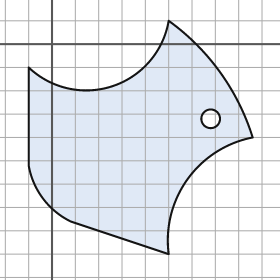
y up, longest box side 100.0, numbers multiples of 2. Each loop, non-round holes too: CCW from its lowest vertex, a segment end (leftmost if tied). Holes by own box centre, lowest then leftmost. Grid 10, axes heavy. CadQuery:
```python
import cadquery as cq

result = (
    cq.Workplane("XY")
    .moveTo(50.0, -90.0)
    .threePointArc((58.0, -58.0), (86.0, -40.0))
    .threePointArc((72.0, -12.0), (50.0, 10.0))
    .threePointArc((26.0, -18.0), (-10.0, -10.0))
    .lineTo(-10.0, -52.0)
    .threePointArc((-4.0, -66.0), (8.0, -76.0))
    .close()
    .moveTo(68.0, -32.0)
    .circle(4.0)
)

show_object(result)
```